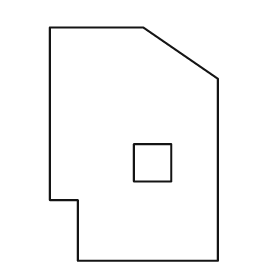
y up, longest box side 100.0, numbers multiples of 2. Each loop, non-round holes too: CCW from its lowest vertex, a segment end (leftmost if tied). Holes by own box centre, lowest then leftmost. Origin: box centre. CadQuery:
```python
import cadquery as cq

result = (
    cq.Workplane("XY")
    .moveTo(-24.0, -50.0)
    .lineTo(36.0, -50.0)
    .lineTo(36.0, 28.0)
    .lineTo(4.0, 50.0)
    .lineTo(-36.0, 50.0)
    .lineTo(-36.0, -24.0)
    .lineTo(-24.0, -24.0)
    .close()
    .moveTo(0.0, -16.0)
    .lineTo(16.0, -16.0)
    .lineTo(16.0, 0.0)
    .lineTo(0.0, 0.0)
    .close()
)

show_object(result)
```